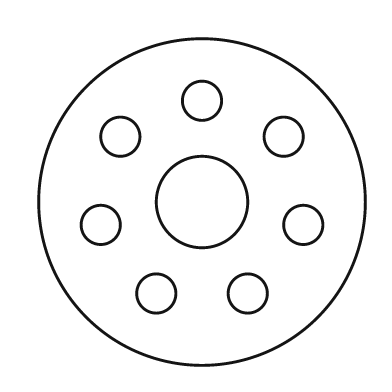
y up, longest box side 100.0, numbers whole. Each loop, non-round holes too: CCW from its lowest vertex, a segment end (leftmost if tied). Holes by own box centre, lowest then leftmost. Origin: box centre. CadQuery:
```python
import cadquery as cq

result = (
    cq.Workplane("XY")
    .moveTo(0.0, 0.0)
    .circle(50.0)
    .moveTo(-14.0, -28.0)
    .circle(6.0)
    .moveTo(14.0, -28.0)
    .circle(6.0)
    .moveTo(-31.0, -7.0)
    .circle(6.0)
    .moveTo(31.0, -7.0)
    .circle(6.0)
    .moveTo(0.0, 0.0)
    .circle(14.0)
    .moveTo(-25.0, 20.0)
    .circle(6.0)
    .moveTo(25.0, 20.0)
    .circle(6.0)
    .moveTo(0.0, 31.0)
    .circle(6.0)
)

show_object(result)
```